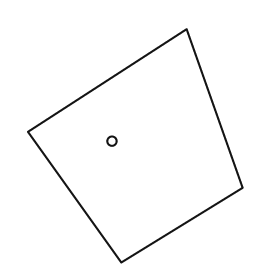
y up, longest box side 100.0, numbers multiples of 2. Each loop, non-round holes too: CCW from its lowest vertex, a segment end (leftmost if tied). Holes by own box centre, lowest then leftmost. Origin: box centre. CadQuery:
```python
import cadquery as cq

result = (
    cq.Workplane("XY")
    .moveTo(-6.0, -50.0)
    .lineTo(46.0, -18.0)
    .lineTo(22.0, 50.0)
    .lineTo(-46.0, 6.0)
    .close()
    .moveTo(-10.0, 2.0)
    .circle(2.0)
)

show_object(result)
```